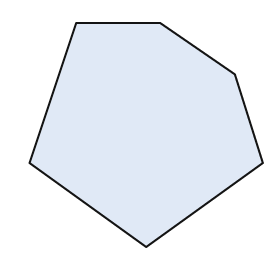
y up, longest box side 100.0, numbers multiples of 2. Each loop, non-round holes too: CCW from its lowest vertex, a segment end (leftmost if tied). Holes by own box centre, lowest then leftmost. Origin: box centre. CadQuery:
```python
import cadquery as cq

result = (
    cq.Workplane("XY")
    .moveTo(0.0, -48.0)
    .lineTo(50.0, -12.0)
    .lineTo(38.0, 26.0)
    .lineTo(6.0, 48.0)
    .lineTo(-30.0, 48.0)
    .lineTo(-50.0, -12.0)
    .close()
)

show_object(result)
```